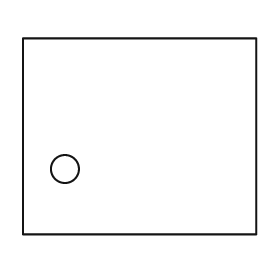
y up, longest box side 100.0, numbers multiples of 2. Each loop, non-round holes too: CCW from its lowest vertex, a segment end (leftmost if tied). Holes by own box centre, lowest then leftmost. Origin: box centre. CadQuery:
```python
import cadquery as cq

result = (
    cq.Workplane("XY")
    .moveTo(-50.0, -42.0)
    .lineTo(50.0, -42.0)
    .lineTo(50.0, 42.0)
    .lineTo(-50.0, 42.0)
    .close()
    .moveTo(-32.0, -14.0)
    .circle(6.0)
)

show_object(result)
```